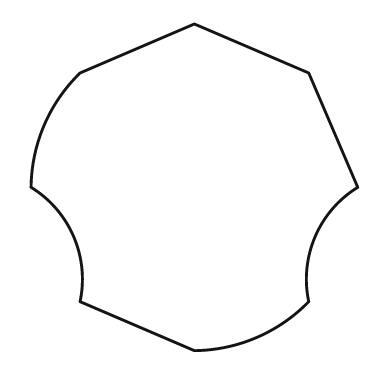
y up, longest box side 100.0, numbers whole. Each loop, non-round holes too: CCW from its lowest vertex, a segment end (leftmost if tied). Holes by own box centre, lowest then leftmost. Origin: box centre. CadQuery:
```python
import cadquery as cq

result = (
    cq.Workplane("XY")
    .moveTo(0.0, -50.0)
    .threePointArc((19.0, -46.0), (35.0, -35.0))
    .threePointArc((37.0, -15.0), (50.0, 0.0))
    .lineTo(35.0, 35.0)
    .lineTo(0.0, 50.0)
    .lineTo(-35.0, 35.0)
    .threePointArc((-46.0, 19.0), (-50.0, 0.0))
    .threePointArc((-37.0, -15.0), (-35.0, -35.0))
    .close()
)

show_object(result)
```